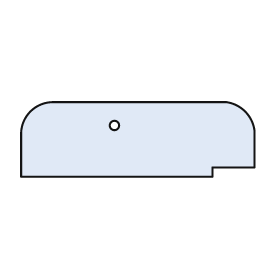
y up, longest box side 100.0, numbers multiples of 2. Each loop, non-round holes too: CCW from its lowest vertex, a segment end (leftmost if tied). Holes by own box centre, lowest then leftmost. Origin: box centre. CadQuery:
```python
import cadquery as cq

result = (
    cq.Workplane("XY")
    .moveTo(-50.0, -16.0)
    .lineTo(32.0, -16.0)
    .lineTo(32.0, -12.0)
    .lineTo(50.0, -12.0)
    .lineTo(50.0, 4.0)
    .threePointArc((46.0, 12.0), (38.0, 16.0))
    .lineTo(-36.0, 16.0)
    .threePointArc((-46.0, 12.0), (-50.0, 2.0))
    .close()
    .moveTo(-10.0, 6.0)
    .circle(2.0)
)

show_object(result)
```